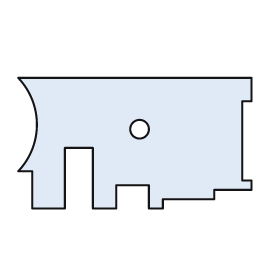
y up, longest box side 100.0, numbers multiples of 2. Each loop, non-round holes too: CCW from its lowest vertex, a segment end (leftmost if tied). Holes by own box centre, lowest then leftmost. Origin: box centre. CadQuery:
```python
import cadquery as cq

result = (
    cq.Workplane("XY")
    .moveTo(-44.0, -28.0)
    .lineTo(-30.0, -28.0)
    .lineTo(-30.0, -2.0)
    .lineTo(-18.0, -2.0)
    .lineTo(-18.0, -28.0)
    .lineTo(-8.0, -28.0)
    .lineTo(-8.0, -18.0)
    .lineTo(6.0, -18.0)
    .lineTo(6.0, -28.0)
    .lineTo(12.0, -28.0)
    .lineTo(12.0, -24.0)
    .lineTo(34.0, -24.0)
    .lineTo(34.0, -20.0)
    .lineTo(50.0, -20.0)
    .lineTo(50.0, -16.0)
    .lineTo(46.0, -16.0)
    .lineTo(46.0, 18.0)
    .lineTo(50.0, 18.0)
    .lineTo(50.0, 28.0)
    .lineTo(-50.0, 28.0)
    .threePointArc((-42.0, 8.0), (-50.0, -12.0))
    .lineTo(-44.0, -12.0)
    .close()
    .moveTo(2.0, 6.0)
    .circle(4.0)
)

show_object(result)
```